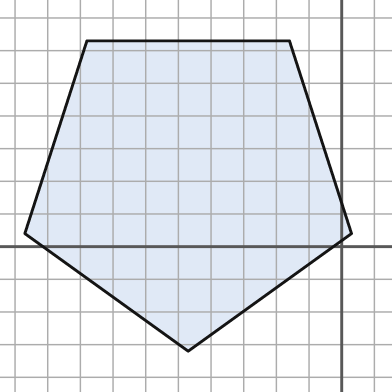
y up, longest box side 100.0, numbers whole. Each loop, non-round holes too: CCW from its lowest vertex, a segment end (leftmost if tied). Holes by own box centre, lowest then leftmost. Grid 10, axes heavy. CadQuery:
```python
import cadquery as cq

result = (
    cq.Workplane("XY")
    .moveTo(-47.0, -32.0)
    .lineTo(3.0, 4.0)
    .lineTo(-16.0, 63.0)
    .lineTo(-78.0, 63.0)
    .lineTo(-97.0, 4.0)
    .close()
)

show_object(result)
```